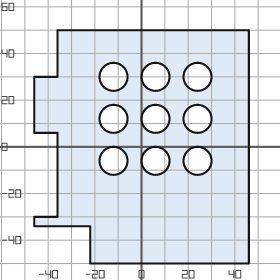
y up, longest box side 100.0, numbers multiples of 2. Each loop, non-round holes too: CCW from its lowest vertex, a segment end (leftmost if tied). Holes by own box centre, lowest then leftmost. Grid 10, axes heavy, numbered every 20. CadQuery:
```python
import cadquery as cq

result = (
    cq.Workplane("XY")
    .moveTo(-22.0, -50.0)
    .lineTo(46.0, -50.0)
    .lineTo(46.0, 50.0)
    .lineTo(-36.0, 50.0)
    .lineTo(-36.0, 30.0)
    .lineTo(-46.0, 30.0)
    .lineTo(-46.0, 6.0)
    .lineTo(-36.0, 6.0)
    .lineTo(-36.0, -30.0)
    .lineTo(-46.0, -30.0)
    .lineTo(-46.0, -34.0)
    .lineTo(-22.0, -34.0)
    .close()
    .moveTo(-12.0, -6.0)
    .circle(6.0)
    .moveTo(6.0, -6.0)
    .circle(6.0)
    .moveTo(24.0, -6.0)
    .circle(6.0)
    .moveTo(-12.0, 12.0)
    .circle(6.0)
    .moveTo(6.0, 12.0)
    .circle(6.0)
    .moveTo(24.0, 12.0)
    .circle(6.0)
    .moveTo(-12.0, 30.0)
    .circle(6.0)
    .moveTo(6.0, 30.0)
    .circle(6.0)
    .moveTo(24.0, 30.0)
    .circle(6.0)
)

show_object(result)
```